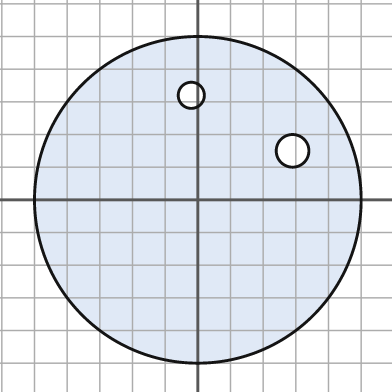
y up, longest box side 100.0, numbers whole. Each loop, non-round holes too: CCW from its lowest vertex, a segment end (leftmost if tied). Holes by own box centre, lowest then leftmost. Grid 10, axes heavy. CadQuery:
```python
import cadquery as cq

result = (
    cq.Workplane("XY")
    .moveTo(0.0, 0.0)
    .circle(50.0)
    .moveTo(29.0, 15.0)
    .circle(5.0)
    .moveTo(-2.0, 32.0)
    .circle(4.0)
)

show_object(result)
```